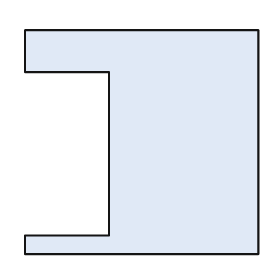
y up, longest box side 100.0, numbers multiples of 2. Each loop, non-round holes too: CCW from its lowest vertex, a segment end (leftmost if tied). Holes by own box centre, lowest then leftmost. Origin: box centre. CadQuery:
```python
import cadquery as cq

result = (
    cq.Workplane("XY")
    .moveTo(-50.0, -48.0)
    .lineTo(50.0, -48.0)
    .lineTo(50.0, 48.0)
    .lineTo(-50.0, 48.0)
    .lineTo(-50.0, 30.0)
    .lineTo(-14.0, 30.0)
    .lineTo(-14.0, -40.0)
    .lineTo(-50.0, -40.0)
    .close()
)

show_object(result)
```